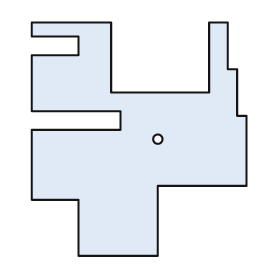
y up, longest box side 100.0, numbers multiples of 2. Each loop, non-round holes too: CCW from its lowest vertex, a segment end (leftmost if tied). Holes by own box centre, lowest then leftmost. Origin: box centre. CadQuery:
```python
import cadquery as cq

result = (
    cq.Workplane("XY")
    .moveTo(-26.0, -50.0)
    .lineTo(8.0, -50.0)
    .lineTo(8.0, -20.0)
    .lineTo(46.0, -20.0)
    .lineTo(46.0, 10.0)
    .lineTo(42.0, 10.0)
    .lineTo(42.0, 30.0)
    .lineTo(38.0, 30.0)
    .lineTo(38.0, 50.0)
    .lineTo(30.0, 50.0)
    .lineTo(30.0, 20.0)
    .lineTo(-12.0, 20.0)
    .lineTo(-12.0, 50.0)
    .lineTo(-46.0, 50.0)
    .lineTo(-46.0, 44.0)
    .lineTo(-26.0, 44.0)
    .lineTo(-26.0, 36.0)
    .lineTo(-46.0, 36.0)
    .lineTo(-46.0, 12.0)
    .lineTo(-8.0, 12.0)
    .lineTo(-8.0, 4.0)
    .lineTo(-46.0, 4.0)
    .lineTo(-46.0, -26.0)
    .lineTo(-26.0, -26.0)
    .close()
    .moveTo(8.0, 0.0)
    .circle(2.0)
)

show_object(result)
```